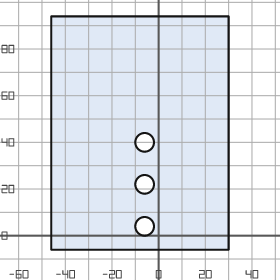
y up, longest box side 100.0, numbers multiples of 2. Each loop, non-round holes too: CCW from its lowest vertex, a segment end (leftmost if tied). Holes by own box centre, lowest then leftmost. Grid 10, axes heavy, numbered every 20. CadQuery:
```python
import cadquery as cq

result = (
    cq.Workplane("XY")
    .moveTo(-46.0, -6.0)
    .lineTo(30.0, -6.0)
    .lineTo(30.0, 94.0)
    .lineTo(-46.0, 94.0)
    .close()
    .moveTo(-6.0, 4.0)
    .circle(4.0)
    .moveTo(-6.0, 22.0)
    .circle(4.0)
    .moveTo(-6.0, 40.0)
    .circle(4.0)
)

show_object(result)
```